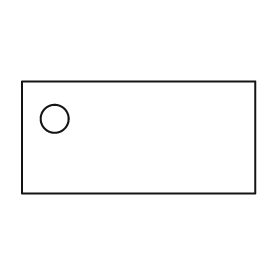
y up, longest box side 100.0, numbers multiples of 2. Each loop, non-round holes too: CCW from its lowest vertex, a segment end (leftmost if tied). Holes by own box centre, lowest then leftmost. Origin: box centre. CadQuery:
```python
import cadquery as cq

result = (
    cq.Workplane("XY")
    .moveTo(-50.0, -24.0)
    .lineTo(50.0, -24.0)
    .lineTo(50.0, 24.0)
    .lineTo(-50.0, 24.0)
    .close()
    .moveTo(-36.0, 8.0)
    .circle(6.0)
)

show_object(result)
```